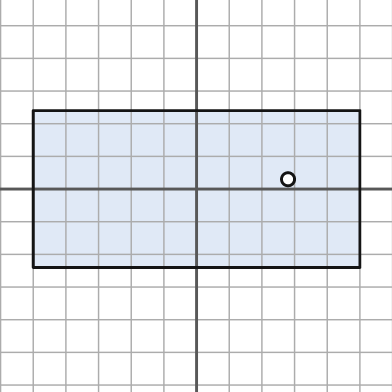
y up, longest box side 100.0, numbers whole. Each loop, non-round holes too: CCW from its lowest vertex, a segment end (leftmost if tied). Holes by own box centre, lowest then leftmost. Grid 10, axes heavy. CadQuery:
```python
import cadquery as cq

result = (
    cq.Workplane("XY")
    .moveTo(-50.0, -24.0)
    .lineTo(50.0, -24.0)
    .lineTo(50.0, 24.0)
    .lineTo(-50.0, 24.0)
    .close()
    .moveTo(28.0, 3.0)
    .circle(2.0)
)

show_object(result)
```